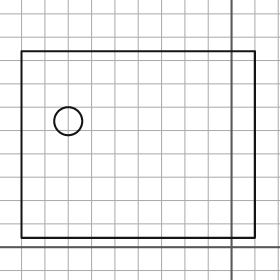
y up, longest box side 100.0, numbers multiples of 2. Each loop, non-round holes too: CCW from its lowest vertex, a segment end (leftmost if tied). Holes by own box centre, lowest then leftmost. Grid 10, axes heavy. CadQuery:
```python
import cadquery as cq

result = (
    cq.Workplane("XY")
    .moveTo(-90.0, 4.0)
    .lineTo(10.0, 4.0)
    .lineTo(10.0, 84.0)
    .lineTo(-90.0, 84.0)
    .close()
    .moveTo(-70.0, 54.0)
    .circle(6.0)
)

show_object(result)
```